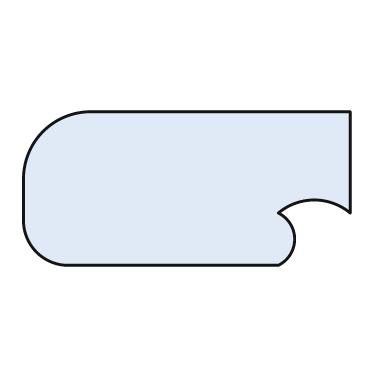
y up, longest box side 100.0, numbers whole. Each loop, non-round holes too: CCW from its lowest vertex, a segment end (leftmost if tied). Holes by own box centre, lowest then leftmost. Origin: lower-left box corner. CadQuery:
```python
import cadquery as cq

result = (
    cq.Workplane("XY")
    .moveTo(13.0, 0.0)
    .lineTo(78.0, 0.0)
    .threePointArc((83.0, 8.0), (78.0, 16.0))
    .threePointArc((89.0, 20.0), (100.0, 16.0))
    .lineTo(100.0, 47.0)
    .lineTo(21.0, 47.0)
    .threePointArc((6.0, 41.0), (0.0, 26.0))
    .lineTo(0.0, 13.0)
    .threePointArc((4.0, 4.0), (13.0, 0.0))
    .close()
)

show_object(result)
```